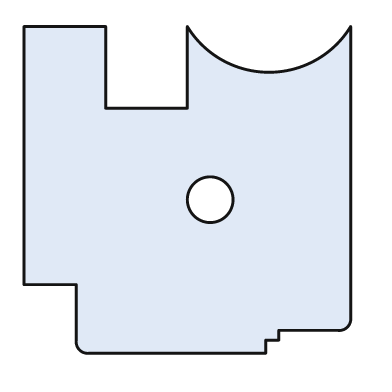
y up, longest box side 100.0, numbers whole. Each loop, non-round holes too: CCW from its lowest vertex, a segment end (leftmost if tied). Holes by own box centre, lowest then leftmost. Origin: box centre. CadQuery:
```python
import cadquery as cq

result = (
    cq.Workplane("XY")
    .moveTo(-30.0, -50.0)
    .lineTo(24.0, -50.0)
    .lineTo(24.0, -46.0)
    .lineTo(28.0, -46.0)
    .lineTo(28.0, -43.0)
    .lineTo(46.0, -43.0)
    .threePointArc((49.0, -42.0), (50.0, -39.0))
    .lineTo(50.0, 50.0)
    .threePointArc((25.0, 36.0), (0.0, 50.0))
    .lineTo(0.0, 25.0)
    .lineTo(-25.0, 25.0)
    .lineTo(-25.0, 50.0)
    .lineTo(-50.0, 50.0)
    .lineTo(-50.0, -29.0)
    .lineTo(-34.0, -29.0)
    .lineTo(-34.0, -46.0)
    .threePointArc((-33.0, -49.0), (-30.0, -50.0))
    .close()
    .moveTo(7.0, -3.0)
    .circle(7.0)
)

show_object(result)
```